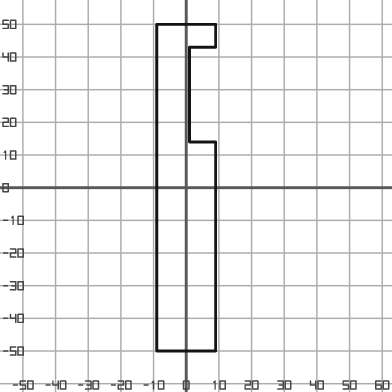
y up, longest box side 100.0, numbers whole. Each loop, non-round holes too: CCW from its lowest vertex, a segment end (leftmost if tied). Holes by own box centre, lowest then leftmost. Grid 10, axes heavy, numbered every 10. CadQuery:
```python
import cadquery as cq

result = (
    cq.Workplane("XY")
    .moveTo(-9.0, -50.0)
    .lineTo(9.0, -50.0)
    .lineTo(9.0, 14.0)
    .lineTo(1.0, 14.0)
    .lineTo(1.0, 43.0)
    .lineTo(9.0, 43.0)
    .lineTo(9.0, 50.0)
    .lineTo(-9.0, 50.0)
    .close()
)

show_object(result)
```